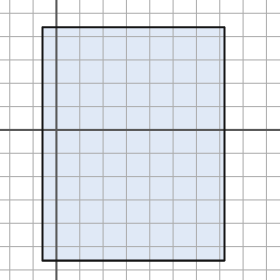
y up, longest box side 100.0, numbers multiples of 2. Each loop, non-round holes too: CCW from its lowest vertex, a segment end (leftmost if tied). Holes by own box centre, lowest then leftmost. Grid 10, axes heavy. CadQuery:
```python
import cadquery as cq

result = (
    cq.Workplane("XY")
    .moveTo(-6.0, -56.0)
    .lineTo(72.0, -56.0)
    .lineTo(72.0, 44.0)
    .lineTo(-6.0, 44.0)
    .close()
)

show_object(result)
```